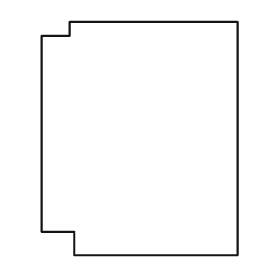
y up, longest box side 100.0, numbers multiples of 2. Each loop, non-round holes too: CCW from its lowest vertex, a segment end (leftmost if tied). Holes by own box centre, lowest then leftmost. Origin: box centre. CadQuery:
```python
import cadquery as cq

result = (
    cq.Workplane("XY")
    .moveTo(-28.0, -50.0)
    .lineTo(42.0, -50.0)
    .lineTo(42.0, 50.0)
    .lineTo(-30.0, 50.0)
    .lineTo(-30.0, 44.0)
    .lineTo(-42.0, 44.0)
    .lineTo(-42.0, -40.0)
    .lineTo(-28.0, -40.0)
    .close()
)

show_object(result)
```